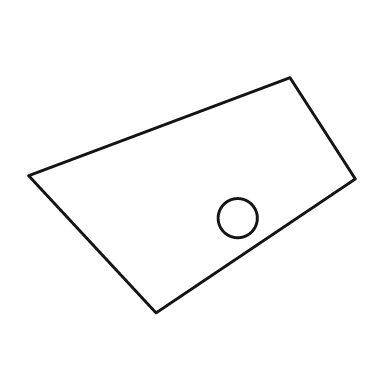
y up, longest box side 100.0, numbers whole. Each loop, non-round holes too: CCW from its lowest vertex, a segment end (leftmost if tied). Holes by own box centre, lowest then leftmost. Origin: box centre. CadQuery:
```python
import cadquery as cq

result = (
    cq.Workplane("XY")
    .moveTo(-11.0, -36.0)
    .lineTo(50.0, 5.0)
    .lineTo(30.0, 36.0)
    .lineTo(-50.0, 6.0)
    .close()
    .moveTo(14.0, -7.0)
    .circle(6.0)
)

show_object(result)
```